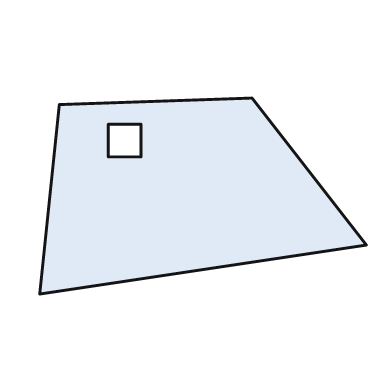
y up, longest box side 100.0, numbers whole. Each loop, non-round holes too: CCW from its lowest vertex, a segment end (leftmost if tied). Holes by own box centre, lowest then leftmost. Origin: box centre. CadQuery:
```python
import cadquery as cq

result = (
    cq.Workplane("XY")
    .moveTo(-50.0, -30.0)
    .lineTo(50.0, -15.0)
    .lineTo(15.0, 30.0)
    .lineTo(-44.0, 28.0)
    .close()
    .moveTo(-29.0, 12.0)
    .lineTo(-19.0, 12.0)
    .lineTo(-19.0, 22.0)
    .lineTo(-29.0, 22.0)
    .close()
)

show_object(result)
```